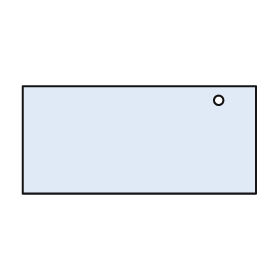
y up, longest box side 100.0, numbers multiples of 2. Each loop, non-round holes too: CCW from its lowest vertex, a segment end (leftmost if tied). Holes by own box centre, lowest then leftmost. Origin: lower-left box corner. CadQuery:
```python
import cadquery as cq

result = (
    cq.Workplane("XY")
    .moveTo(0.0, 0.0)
    .lineTo(100.0, 0.0)
    .lineTo(100.0, 46.0)
    .lineTo(0.0, 46.0)
    .close()
    .moveTo(84.0, 40.0)
    .circle(2.0)
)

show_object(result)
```